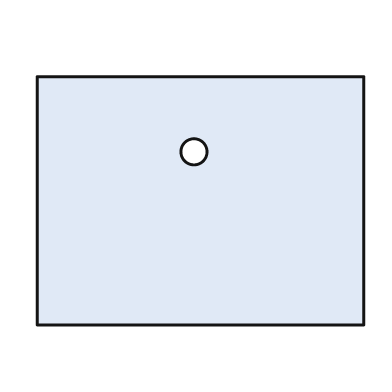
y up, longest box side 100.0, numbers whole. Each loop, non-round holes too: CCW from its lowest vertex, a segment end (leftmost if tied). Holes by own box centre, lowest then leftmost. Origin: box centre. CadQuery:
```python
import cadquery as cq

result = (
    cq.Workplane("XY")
    .moveTo(-50.0, -38.0)
    .lineTo(50.0, -38.0)
    .lineTo(50.0, 38.0)
    .lineTo(-50.0, 38.0)
    .close()
    .moveTo(-2.0, 15.0)
    .circle(4.0)
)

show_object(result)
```